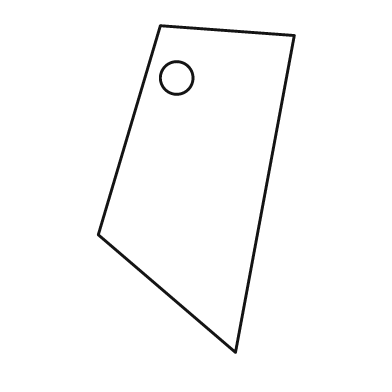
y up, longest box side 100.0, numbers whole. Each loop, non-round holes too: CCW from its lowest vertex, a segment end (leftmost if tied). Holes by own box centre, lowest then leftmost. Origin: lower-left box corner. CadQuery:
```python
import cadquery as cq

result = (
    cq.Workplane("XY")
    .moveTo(42.0, 0.0)
    .lineTo(60.0, 97.0)
    .lineTo(19.0, 100.0)
    .lineTo(0.0, 36.0)
    .close()
    .moveTo(24.0, 84.0)
    .circle(5.0)
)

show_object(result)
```